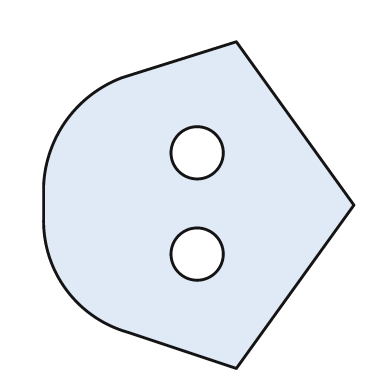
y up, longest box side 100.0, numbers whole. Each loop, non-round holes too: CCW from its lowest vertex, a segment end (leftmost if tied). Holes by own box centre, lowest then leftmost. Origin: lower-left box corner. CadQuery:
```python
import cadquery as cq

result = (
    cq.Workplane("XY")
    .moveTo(59.0, 0.0)
    .lineTo(95.0, 50.0)
    .lineTo(59.0, 100.0)
    .lineTo(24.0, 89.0)
    .threePointArc((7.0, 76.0), (0.0, 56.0))
    .lineTo(0.0, 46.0)
    .threePointArc((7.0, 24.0), (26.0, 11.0))
    .close()
    .moveTo(47.0, 35.0)
    .circle(8.0)
    .moveTo(47.0, 66.0)
    .circle(8.0)
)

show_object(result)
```